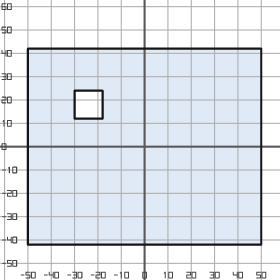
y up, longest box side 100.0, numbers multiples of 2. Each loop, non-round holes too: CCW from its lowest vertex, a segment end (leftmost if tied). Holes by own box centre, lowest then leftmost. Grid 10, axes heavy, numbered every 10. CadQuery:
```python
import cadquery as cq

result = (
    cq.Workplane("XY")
    .moveTo(-50.0, -42.0)
    .lineTo(50.0, -42.0)
    .lineTo(50.0, 42.0)
    .lineTo(-50.0, 42.0)
    .close()
    .moveTo(-30.0, 12.0)
    .lineTo(-18.0, 12.0)
    .lineTo(-18.0, 24.0)
    .lineTo(-30.0, 24.0)
    .close()
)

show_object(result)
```